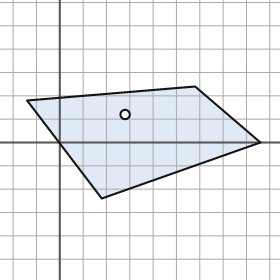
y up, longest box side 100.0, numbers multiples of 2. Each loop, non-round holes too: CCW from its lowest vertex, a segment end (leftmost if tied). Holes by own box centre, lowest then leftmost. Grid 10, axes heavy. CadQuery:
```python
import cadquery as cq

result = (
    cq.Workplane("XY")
    .moveTo(18.0, -24.0)
    .lineTo(86.0, 0.0)
    .lineTo(58.0, 24.0)
    .lineTo(-14.0, 18.0)
    .close()
    .moveTo(28.0, 12.0)
    .circle(2.0)
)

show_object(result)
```